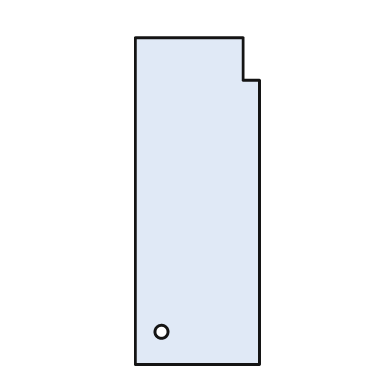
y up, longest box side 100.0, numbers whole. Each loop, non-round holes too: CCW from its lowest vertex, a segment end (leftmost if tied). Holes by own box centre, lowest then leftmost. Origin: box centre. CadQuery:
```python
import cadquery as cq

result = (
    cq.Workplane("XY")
    .moveTo(-19.0, -50.0)
    .lineTo(19.0, -50.0)
    .lineTo(19.0, 37.0)
    .lineTo(14.0, 37.0)
    .lineTo(14.0, 50.0)
    .lineTo(-19.0, 50.0)
    .close()
    .moveTo(-11.0, -40.0)
    .circle(2.0)
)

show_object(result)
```